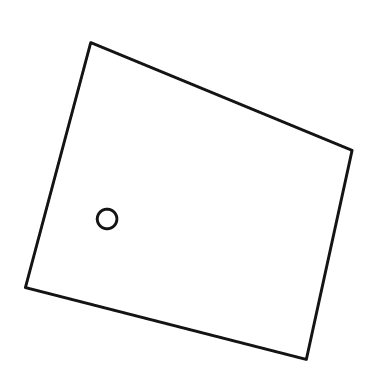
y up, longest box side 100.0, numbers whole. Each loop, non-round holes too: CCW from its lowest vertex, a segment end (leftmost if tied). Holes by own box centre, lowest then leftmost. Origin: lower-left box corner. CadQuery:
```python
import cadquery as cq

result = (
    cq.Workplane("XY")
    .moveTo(86.0, 0.0)
    .lineTo(100.0, 64.0)
    .lineTo(20.0, 97.0)
    .lineTo(0.0, 22.0)
    .close()
    .moveTo(25.0, 43.0)
    .circle(3.0)
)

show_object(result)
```